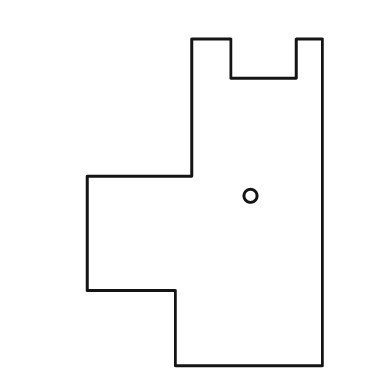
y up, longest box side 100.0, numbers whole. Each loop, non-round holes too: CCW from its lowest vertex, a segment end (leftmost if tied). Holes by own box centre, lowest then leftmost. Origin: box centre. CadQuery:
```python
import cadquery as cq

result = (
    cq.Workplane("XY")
    .moveTo(-9.0, -50.0)
    .lineTo(36.0, -50.0)
    .lineTo(36.0, 50.0)
    .lineTo(28.0, 50.0)
    .lineTo(28.0, 38.0)
    .lineTo(8.0, 38.0)
    .lineTo(8.0, 50.0)
    .lineTo(-4.0, 50.0)
    .lineTo(-4.0, 8.0)
    .lineTo(-36.0, 8.0)
    .lineTo(-36.0, -27.0)
    .lineTo(-9.0, -27.0)
    .close()
    .moveTo(14.0, 2.0)
    .circle(2.0)
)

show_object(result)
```